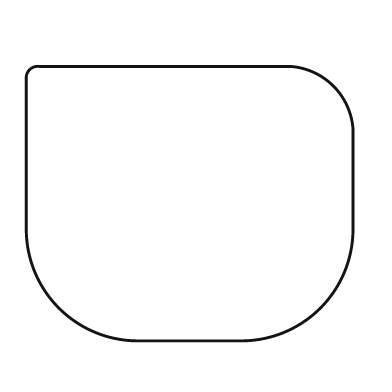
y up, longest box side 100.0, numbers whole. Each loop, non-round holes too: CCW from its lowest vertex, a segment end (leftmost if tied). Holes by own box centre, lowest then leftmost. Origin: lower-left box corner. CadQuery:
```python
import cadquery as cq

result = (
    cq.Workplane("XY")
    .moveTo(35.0, 0.0)
    .lineTo(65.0, 0.0)
    .threePointArc((90.0, 10.0), (100.0, 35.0))
    .lineTo(100.0, 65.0)
    .threePointArc((94.0, 78.0), (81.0, 84.0))
    .lineTo(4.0, 84.0)
    .threePointArc((1.0, 83.0), (0.0, 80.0))
    .lineTo(0.0, 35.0)
    .threePointArc((10.0, 10.0), (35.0, 0.0))
    .close()
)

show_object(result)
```